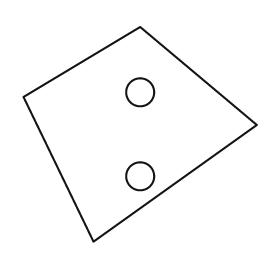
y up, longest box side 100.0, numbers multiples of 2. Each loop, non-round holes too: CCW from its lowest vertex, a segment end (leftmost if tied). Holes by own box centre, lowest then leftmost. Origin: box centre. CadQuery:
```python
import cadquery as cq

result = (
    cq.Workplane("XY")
    .moveTo(-20.0, -46.0)
    .lineTo(50.0, 4.0)
    .lineTo(0.0, 46.0)
    .lineTo(-50.0, 16.0)
    .close()
    .moveTo(0.0, -18.0)
    .circle(6.0)
    .moveTo(0.0, 18.0)
    .circle(6.0)
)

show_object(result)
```